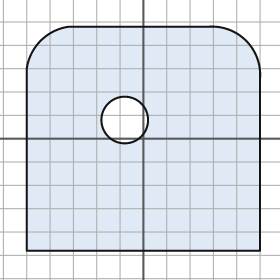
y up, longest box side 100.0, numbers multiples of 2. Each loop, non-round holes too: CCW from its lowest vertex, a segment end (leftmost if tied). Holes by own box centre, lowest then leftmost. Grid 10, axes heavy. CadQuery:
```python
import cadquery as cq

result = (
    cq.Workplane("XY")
    .moveTo(-50.0, -48.0)
    .lineTo(50.0, -48.0)
    .lineTo(50.0, 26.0)
    .threePointArc((44.0, 42.0), (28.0, 48.0))
    .lineTo(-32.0, 48.0)
    .threePointArc((-44.0, 42.0), (-50.0, 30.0))
    .close()
    .moveTo(-8.0, 8.0)
    .circle(10.0)
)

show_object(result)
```